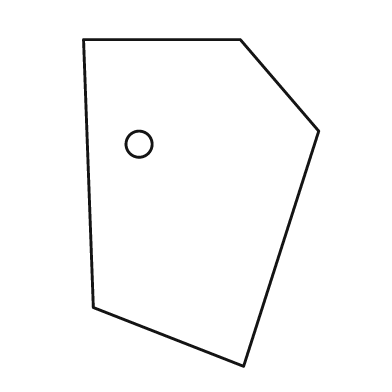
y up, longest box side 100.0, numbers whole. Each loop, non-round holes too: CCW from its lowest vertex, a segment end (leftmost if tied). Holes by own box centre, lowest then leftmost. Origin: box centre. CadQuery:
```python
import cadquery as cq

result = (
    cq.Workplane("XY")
    .moveTo(13.0, -50.0)
    .lineTo(36.0, 22.0)
    .lineTo(12.0, 50.0)
    .lineTo(-36.0, 50.0)
    .lineTo(-33.0, -32.0)
    .close()
    .moveTo(-19.0, 18.0)
    .circle(4.0)
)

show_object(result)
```